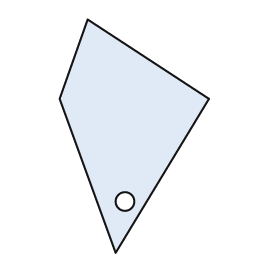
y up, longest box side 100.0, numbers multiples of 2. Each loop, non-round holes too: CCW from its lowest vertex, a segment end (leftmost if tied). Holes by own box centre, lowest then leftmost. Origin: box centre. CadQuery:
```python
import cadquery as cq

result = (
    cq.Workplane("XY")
    .moveTo(-8.0, -50.0)
    .lineTo(32.0, 16.0)
    .lineTo(-20.0, 50.0)
    .lineTo(-32.0, 16.0)
    .close()
    .moveTo(-4.0, -28.0)
    .circle(4.0)
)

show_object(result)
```